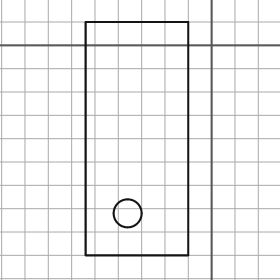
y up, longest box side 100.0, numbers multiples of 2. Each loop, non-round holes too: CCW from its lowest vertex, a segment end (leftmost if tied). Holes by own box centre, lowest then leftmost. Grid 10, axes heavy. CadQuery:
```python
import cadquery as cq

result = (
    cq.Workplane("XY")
    .moveTo(-54.0, -90.0)
    .lineTo(-10.0, -90.0)
    .lineTo(-10.0, 10.0)
    .lineTo(-54.0, 10.0)
    .close()
    .moveTo(-36.0, -72.0)
    .circle(6.0)
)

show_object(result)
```